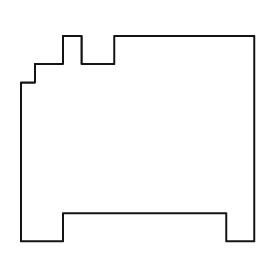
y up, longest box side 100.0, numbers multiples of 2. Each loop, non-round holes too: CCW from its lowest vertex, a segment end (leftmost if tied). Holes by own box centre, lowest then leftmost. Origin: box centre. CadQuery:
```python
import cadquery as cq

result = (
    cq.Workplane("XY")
    .moveTo(-50.0, -44.0)
    .lineTo(-32.0, -44.0)
    .lineTo(-32.0, -32.0)
    .lineTo(38.0, -32.0)
    .lineTo(38.0, -44.0)
    .lineTo(50.0, -44.0)
    .lineTo(50.0, 44.0)
    .lineTo(-10.0, 44.0)
    .lineTo(-10.0, 32.0)
    .lineTo(-24.0, 32.0)
    .lineTo(-24.0, 44.0)
    .lineTo(-32.0, 44.0)
    .lineTo(-32.0, 32.0)
    .lineTo(-44.0, 32.0)
    .lineTo(-44.0, 24.0)
    .lineTo(-50.0, 24.0)
    .close()
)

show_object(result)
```